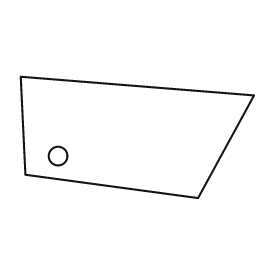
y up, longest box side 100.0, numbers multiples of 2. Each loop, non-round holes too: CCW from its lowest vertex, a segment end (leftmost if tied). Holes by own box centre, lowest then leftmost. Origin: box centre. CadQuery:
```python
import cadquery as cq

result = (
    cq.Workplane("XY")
    .moveTo(26.0, -26.0)
    .lineTo(50.0, 18.0)
    .lineTo(-50.0, 26.0)
    .lineTo(-48.0, -16.0)
    .close()
    .moveTo(-34.0, -8.0)
    .circle(4.0)
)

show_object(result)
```